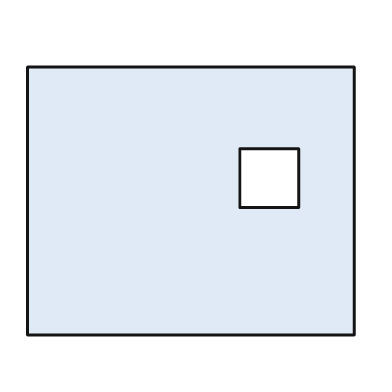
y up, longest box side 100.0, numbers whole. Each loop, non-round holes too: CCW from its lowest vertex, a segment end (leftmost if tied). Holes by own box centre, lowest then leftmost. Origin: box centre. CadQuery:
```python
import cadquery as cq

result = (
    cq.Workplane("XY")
    .moveTo(-50.0, -41.0)
    .lineTo(50.0, -41.0)
    .lineTo(50.0, 41.0)
    .lineTo(-50.0, 41.0)
    .close()
    .moveTo(15.0, -2.0)
    .lineTo(33.0, -2.0)
    .lineTo(33.0, 16.0)
    .lineTo(15.0, 16.0)
    .close()
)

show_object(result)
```